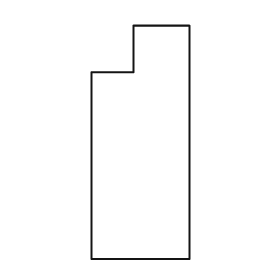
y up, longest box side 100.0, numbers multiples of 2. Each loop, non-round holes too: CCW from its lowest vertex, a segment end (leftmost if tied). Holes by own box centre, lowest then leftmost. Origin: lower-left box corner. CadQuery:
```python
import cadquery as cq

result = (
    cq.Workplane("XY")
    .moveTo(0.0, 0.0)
    .lineTo(42.0, 0.0)
    .lineTo(42.0, 100.0)
    .lineTo(18.0, 100.0)
    .lineTo(18.0, 80.0)
    .lineTo(0.0, 80.0)
    .close()
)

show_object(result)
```